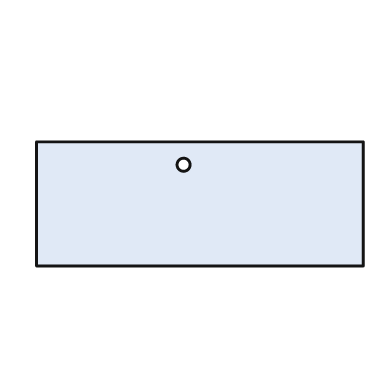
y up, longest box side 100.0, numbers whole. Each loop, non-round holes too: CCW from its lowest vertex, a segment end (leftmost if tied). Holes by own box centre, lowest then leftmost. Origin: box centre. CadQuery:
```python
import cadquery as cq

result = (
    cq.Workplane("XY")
    .moveTo(-50.0, -19.0)
    .lineTo(50.0, -19.0)
    .lineTo(50.0, 19.0)
    .lineTo(-50.0, 19.0)
    .close()
    .moveTo(-5.0, 12.0)
    .circle(2.0)
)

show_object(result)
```